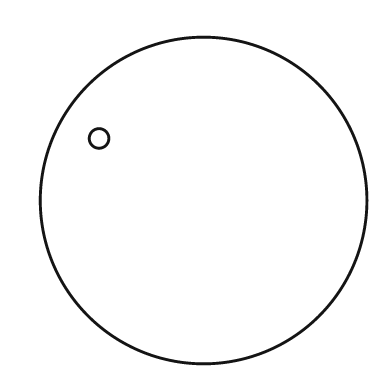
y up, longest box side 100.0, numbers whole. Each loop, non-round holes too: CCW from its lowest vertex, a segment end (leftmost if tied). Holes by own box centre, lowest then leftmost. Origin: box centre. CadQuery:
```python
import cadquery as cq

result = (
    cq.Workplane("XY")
    .moveTo(0.0, 0.0)
    .circle(50.0)
    .moveTo(-32.0, 19.0)
    .circle(3.0)
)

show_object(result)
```